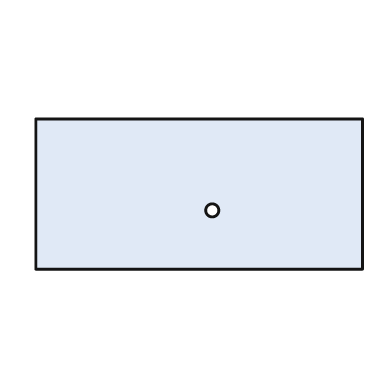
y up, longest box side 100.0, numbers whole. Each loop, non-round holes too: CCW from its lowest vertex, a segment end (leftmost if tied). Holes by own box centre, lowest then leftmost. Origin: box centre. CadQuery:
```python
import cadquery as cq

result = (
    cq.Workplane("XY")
    .moveTo(-50.0, -23.0)
    .lineTo(50.0, -23.0)
    .lineTo(50.0, 23.0)
    .lineTo(-50.0, 23.0)
    .close()
    .moveTo(4.0, -5.0)
    .circle(2.0)
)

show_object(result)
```